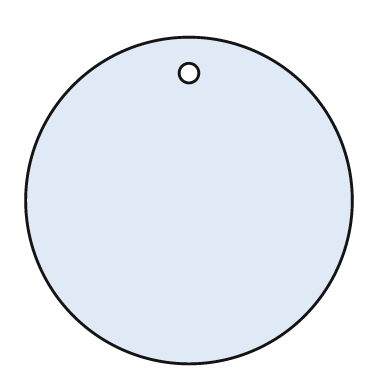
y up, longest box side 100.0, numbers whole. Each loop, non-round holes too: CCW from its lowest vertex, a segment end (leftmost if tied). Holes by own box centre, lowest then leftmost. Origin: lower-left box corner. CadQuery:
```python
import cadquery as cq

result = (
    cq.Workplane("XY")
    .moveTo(50.0, 50.0)
    .circle(50.0)
    .moveTo(50.0, 89.0)
    .circle(3.0)
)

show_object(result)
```